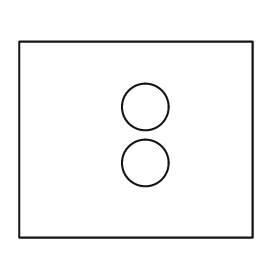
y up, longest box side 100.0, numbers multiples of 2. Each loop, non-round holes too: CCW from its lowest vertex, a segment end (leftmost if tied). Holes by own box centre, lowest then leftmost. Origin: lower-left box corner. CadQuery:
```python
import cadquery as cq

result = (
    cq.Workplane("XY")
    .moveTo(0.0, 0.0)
    .lineTo(100.0, 0.0)
    .lineTo(100.0, 84.0)
    .lineTo(0.0, 84.0)
    .close()
    .moveTo(54.0, 32.0)
    .circle(10.0)
    .moveTo(54.0, 56.0)
    .circle(10.0)
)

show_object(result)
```